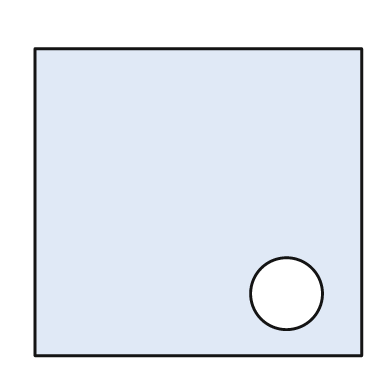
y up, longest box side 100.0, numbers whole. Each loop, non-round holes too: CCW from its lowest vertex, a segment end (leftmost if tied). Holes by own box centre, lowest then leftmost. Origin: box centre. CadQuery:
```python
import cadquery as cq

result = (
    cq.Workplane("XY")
    .moveTo(-50.0, -47.0)
    .lineTo(50.0, -47.0)
    .lineTo(50.0, 47.0)
    .lineTo(-50.0, 47.0)
    .close()
    .moveTo(27.0, -28.0)
    .circle(11.0)
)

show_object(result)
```